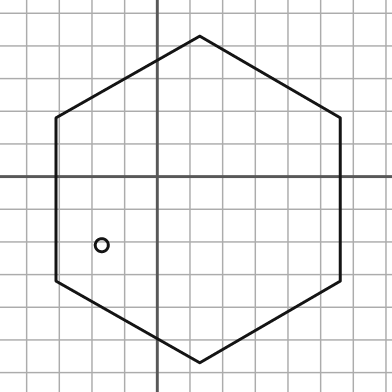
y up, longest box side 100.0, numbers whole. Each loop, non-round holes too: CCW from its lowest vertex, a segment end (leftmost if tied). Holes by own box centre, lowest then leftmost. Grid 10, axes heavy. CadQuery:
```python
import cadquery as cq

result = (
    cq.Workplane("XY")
    .moveTo(13.0, -57.0)
    .lineTo(56.0, -32.0)
    .lineTo(56.0, 18.0)
    .lineTo(13.0, 43.0)
    .lineTo(-31.0, 18.0)
    .lineTo(-31.0, -32.0)
    .close()
    .moveTo(-17.0, -21.0)
    .circle(2.0)
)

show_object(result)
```